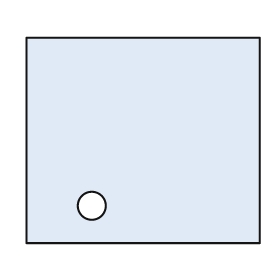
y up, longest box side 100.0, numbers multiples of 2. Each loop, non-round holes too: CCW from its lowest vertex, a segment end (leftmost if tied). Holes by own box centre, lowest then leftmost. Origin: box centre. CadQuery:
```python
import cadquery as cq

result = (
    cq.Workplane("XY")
    .moveTo(-50.0, -44.0)
    .lineTo(50.0, -44.0)
    .lineTo(50.0, 44.0)
    .lineTo(-50.0, 44.0)
    .close()
    .moveTo(-22.0, -28.0)
    .circle(6.0)
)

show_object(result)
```